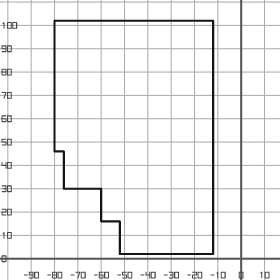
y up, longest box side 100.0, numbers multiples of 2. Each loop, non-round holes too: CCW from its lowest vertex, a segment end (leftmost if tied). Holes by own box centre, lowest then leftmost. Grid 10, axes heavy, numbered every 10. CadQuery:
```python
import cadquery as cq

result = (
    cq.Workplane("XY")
    .moveTo(-52.0, 2.0)
    .lineTo(-12.0, 2.0)
    .lineTo(-12.0, 102.0)
    .lineTo(-80.0, 102.0)
    .lineTo(-80.0, 46.0)
    .lineTo(-76.0, 46.0)
    .lineTo(-76.0, 30.0)
    .lineTo(-60.0, 30.0)
    .lineTo(-60.0, 16.0)
    .lineTo(-52.0, 16.0)
    .close()
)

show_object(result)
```